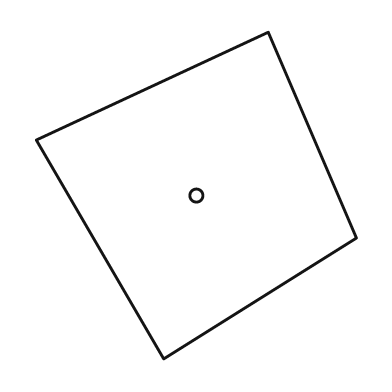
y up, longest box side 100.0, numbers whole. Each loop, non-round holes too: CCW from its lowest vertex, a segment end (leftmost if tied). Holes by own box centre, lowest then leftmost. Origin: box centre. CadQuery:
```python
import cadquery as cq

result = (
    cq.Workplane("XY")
    .moveTo(-10.0, -50.0)
    .lineTo(49.0, -13.0)
    .lineTo(22.0, 50.0)
    .lineTo(-49.0, 17.0)
    .close()
    .moveTo(0.0, 0.0)
    .circle(2.0)
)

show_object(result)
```